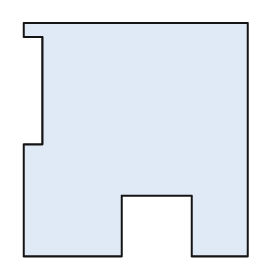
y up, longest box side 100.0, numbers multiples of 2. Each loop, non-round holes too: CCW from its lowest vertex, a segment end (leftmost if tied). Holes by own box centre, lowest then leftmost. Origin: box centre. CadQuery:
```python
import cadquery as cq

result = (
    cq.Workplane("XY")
    .moveTo(-48.0, -50.0)
    .lineTo(-6.0, -50.0)
    .lineTo(-6.0, -24.0)
    .lineTo(24.0, -24.0)
    .lineTo(24.0, -50.0)
    .lineTo(48.0, -50.0)
    .lineTo(48.0, 50.0)
    .lineTo(-48.0, 50.0)
    .lineTo(-48.0, 44.0)
    .lineTo(-40.0, 44.0)
    .lineTo(-40.0, -2.0)
    .lineTo(-48.0, -2.0)
    .close()
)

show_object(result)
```